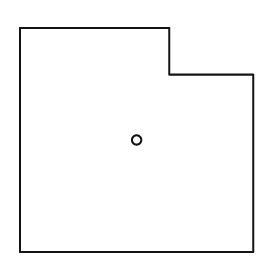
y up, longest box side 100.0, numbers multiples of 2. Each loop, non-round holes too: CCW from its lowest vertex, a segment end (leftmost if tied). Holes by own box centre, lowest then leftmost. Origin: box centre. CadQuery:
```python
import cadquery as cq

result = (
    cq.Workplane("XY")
    .moveTo(-50.0, -48.0)
    .lineTo(50.0, -48.0)
    .lineTo(50.0, 28.0)
    .lineTo(14.0, 28.0)
    .lineTo(14.0, 48.0)
    .lineTo(-50.0, 48.0)
    .close()
    .moveTo(0.0, 0.0)
    .circle(2.0)
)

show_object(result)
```